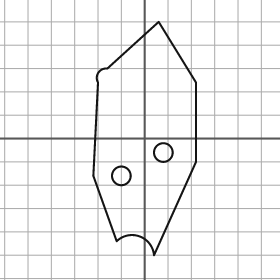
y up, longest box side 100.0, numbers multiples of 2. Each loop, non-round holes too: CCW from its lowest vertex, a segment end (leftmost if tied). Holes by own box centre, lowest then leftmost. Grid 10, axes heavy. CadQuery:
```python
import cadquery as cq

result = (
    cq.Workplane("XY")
    .moveTo(4.0, -50.0)
    .lineTo(22.0, -10.0)
    .lineTo(22.0, 24.0)
    .lineTo(6.0, 50.0)
    .lineTo(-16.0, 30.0)
    .threePointArc((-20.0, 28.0), (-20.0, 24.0))
    .lineTo(-22.0, -16.0)
    .lineTo(-12.0, -44.0)
    .threePointArc((-2.0, -42.0), (4.0, -50.0))
    .close()
    .moveTo(-10.0, -16.0)
    .circle(4.0)
    .moveTo(8.0, -6.0)
    .circle(4.0)
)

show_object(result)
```